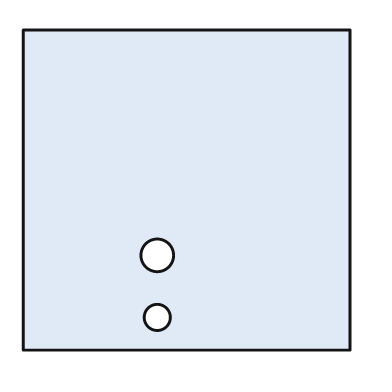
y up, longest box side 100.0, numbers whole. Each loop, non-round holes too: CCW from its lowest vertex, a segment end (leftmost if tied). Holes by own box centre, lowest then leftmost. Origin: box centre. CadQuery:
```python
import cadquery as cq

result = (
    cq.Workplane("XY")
    .moveTo(-50.0, -49.0)
    .lineTo(50.0, -49.0)
    .lineTo(50.0, 49.0)
    .lineTo(-50.0, 49.0)
    .close()
    .moveTo(-9.0, -39.0)
    .circle(4.0)
    .moveTo(-9.0, -20.0)
    .circle(5.0)
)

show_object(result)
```